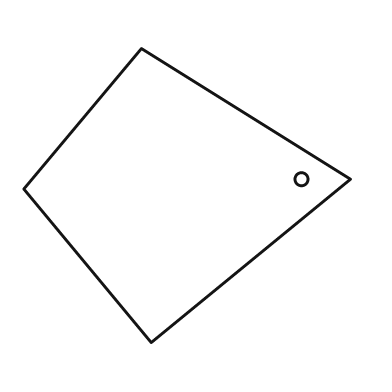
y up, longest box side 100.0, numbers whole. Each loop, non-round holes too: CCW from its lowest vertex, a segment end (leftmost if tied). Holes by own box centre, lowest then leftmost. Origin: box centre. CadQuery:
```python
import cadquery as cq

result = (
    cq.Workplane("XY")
    .moveTo(-11.0, -45.0)
    .lineTo(50.0, 5.0)
    .lineTo(-14.0, 45.0)
    .lineTo(-50.0, 2.0)
    .close()
    .moveTo(35.0, 5.0)
    .circle(2.0)
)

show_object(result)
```